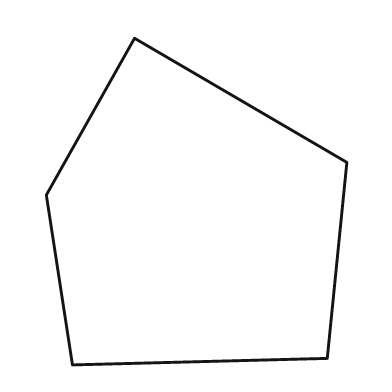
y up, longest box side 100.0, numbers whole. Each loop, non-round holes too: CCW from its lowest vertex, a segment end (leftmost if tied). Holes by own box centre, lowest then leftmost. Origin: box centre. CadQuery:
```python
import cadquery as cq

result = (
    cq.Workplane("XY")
    .moveTo(-38.0, -50.0)
    .lineTo(40.0, -48.0)
    .lineTo(46.0, 12.0)
    .lineTo(-19.0, 50.0)
    .lineTo(-46.0, 2.0)
    .close()
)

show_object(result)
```